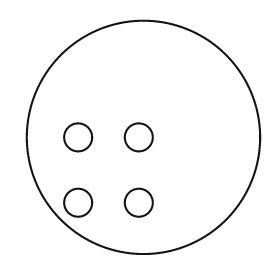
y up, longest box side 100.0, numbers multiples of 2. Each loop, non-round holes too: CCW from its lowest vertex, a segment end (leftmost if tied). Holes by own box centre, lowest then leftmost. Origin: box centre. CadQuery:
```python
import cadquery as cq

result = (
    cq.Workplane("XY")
    .moveTo(0.0, 0.0)
    .circle(50.0)
    .moveTo(-28.0, -28.0)
    .circle(6.0)
    .moveTo(-2.0, -28.0)
    .circle(6.0)
    .moveTo(-28.0, 0.0)
    .circle(6.0)
    .moveTo(-2.0, 0.0)
    .circle(6.0)
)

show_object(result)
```